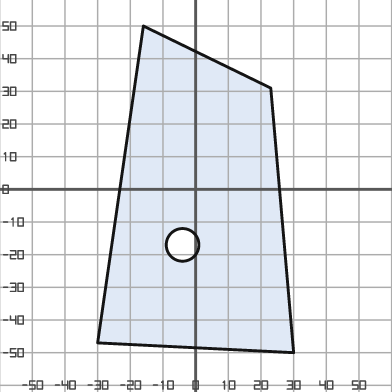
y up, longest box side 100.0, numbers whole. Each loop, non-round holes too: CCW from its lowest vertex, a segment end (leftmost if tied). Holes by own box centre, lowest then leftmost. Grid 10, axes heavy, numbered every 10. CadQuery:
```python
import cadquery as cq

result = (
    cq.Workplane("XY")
    .moveTo(30.0, -50.0)
    .lineTo(23.0, 31.0)
    .lineTo(-16.0, 50.0)
    .lineTo(-30.0, -47.0)
    .close()
    .moveTo(-4.0, -17.0)
    .circle(5.0)
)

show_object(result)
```